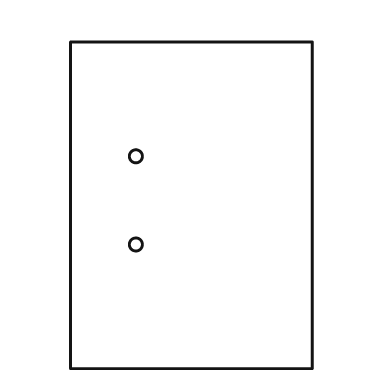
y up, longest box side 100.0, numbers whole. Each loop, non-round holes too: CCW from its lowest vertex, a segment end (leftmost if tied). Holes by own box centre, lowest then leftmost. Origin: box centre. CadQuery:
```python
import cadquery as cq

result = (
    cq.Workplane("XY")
    .moveTo(-37.0, -50.0)
    .lineTo(37.0, -50.0)
    .lineTo(37.0, 50.0)
    .lineTo(-37.0, 50.0)
    .close()
    .moveTo(-17.0, -12.0)
    .circle(2.0)
    .moveTo(-17.0, 15.0)
    .circle(2.0)
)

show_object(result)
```